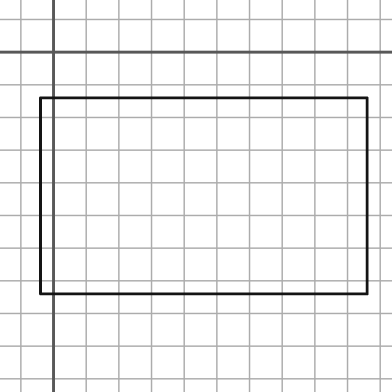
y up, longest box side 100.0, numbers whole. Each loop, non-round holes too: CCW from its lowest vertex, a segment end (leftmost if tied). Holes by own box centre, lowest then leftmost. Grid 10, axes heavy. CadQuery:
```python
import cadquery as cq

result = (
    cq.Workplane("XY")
    .moveTo(-4.0, -74.0)
    .lineTo(96.0, -74.0)
    .lineTo(96.0, -14.0)
    .lineTo(-4.0, -14.0)
    .close()
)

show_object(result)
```